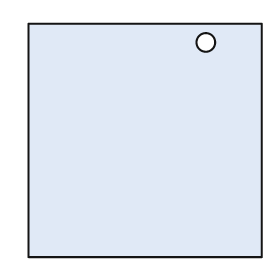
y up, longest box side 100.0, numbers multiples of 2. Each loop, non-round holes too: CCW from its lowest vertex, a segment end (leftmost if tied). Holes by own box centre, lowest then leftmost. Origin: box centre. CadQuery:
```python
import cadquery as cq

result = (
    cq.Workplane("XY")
    .moveTo(-50.0, -50.0)
    .lineTo(50.0, -50.0)
    .lineTo(50.0, 50.0)
    .lineTo(-50.0, 50.0)
    .close()
    .moveTo(26.0, 42.0)
    .circle(4.0)
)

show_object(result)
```